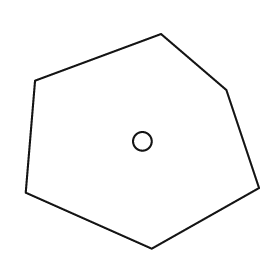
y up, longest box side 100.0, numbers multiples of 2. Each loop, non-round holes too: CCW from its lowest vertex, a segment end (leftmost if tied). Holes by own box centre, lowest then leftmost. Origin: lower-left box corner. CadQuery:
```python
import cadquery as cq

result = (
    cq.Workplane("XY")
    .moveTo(54.0, 0.0)
    .lineTo(100.0, 26.0)
    .lineTo(86.0, 68.0)
    .lineTo(58.0, 92.0)
    .lineTo(4.0, 72.0)
    .lineTo(0.0, 24.0)
    .close()
    .moveTo(50.0, 46.0)
    .circle(4.0)
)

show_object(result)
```